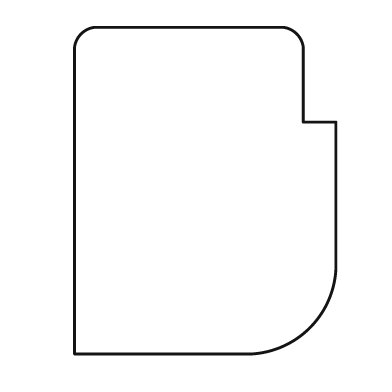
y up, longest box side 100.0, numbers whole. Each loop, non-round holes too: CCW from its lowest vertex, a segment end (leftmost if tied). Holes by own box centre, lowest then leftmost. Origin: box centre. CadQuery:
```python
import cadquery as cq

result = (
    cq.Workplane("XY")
    .moveTo(-40.0, -50.0)
    .lineTo(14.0, -50.0)
    .threePointArc((32.0, -42.0), (40.0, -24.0))
    .lineTo(40.0, 21.0)
    .lineTo(30.0, 21.0)
    .lineTo(30.0, 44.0)
    .threePointArc((28.0, 48.0), (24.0, 50.0))
    .lineTo(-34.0, 50.0)
    .threePointArc((-38.0, 48.0), (-40.0, 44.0))
    .close()
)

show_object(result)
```